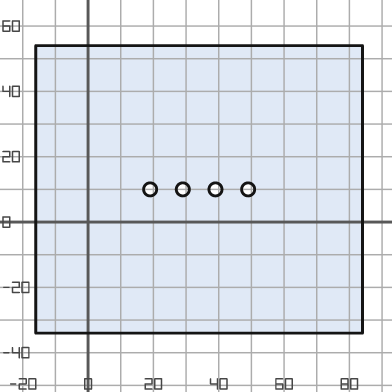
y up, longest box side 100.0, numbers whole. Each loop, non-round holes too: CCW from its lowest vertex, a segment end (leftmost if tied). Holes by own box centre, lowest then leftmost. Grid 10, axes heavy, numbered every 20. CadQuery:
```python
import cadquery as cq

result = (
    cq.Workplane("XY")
    .moveTo(-16.0, -34.0)
    .lineTo(84.0, -34.0)
    .lineTo(84.0, 54.0)
    .lineTo(-16.0, 54.0)
    .close()
    .moveTo(19.0, 10.0)
    .circle(2.0)
    .moveTo(29.0, 10.0)
    .circle(2.0)
    .moveTo(39.0, 10.0)
    .circle(2.0)
    .moveTo(49.0, 10.0)
    .circle(2.0)
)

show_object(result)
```